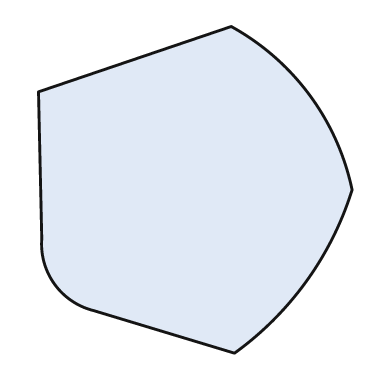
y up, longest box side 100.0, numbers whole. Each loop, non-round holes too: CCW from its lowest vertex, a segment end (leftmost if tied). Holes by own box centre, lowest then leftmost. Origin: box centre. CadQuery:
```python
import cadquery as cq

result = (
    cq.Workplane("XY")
    .moveTo(12.0, -50.0)
    .threePointArc((34.0, -28.0), (48.0, 0.0))
    .threePointArc((35.0, 29.0), (11.0, 50.0))
    .lineTo(-48.0, 30.0)
    .lineTo(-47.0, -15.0)
    .threePointArc((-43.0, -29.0), (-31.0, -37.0))
    .close()
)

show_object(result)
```